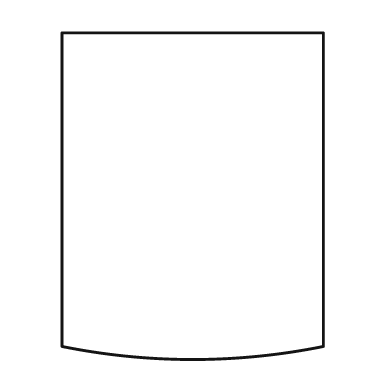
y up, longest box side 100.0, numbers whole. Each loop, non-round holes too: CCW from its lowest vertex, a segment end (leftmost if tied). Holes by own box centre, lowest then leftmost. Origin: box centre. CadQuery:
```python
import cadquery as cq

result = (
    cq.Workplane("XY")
    .moveTo(-40.0, -46.0)
    .threePointArc((0.0, -50.0), (40.0, -46.0))
    .lineTo(40.0, 50.0)
    .lineTo(-40.0, 50.0)
    .close()
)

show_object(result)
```